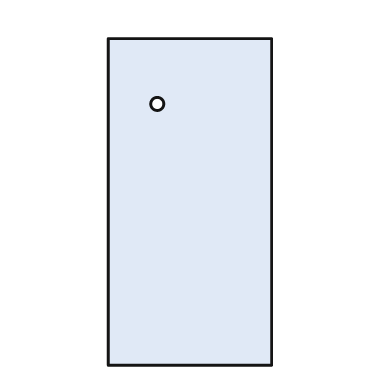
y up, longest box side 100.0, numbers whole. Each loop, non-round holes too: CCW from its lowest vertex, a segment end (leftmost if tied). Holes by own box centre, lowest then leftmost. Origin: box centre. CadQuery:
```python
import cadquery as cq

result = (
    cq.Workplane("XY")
    .moveTo(-25.0, -50.0)
    .lineTo(25.0, -50.0)
    .lineTo(25.0, 50.0)
    .lineTo(-25.0, 50.0)
    .close()
    .moveTo(-10.0, 30.0)
    .circle(2.0)
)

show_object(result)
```